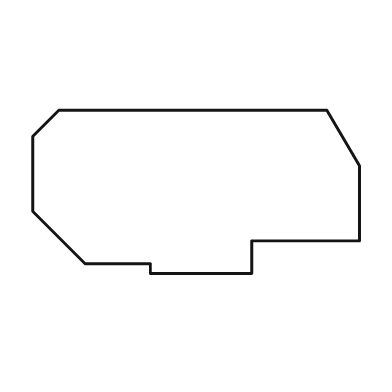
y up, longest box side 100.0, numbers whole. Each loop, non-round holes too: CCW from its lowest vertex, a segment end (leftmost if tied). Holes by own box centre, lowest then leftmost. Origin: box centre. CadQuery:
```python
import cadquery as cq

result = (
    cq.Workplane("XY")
    .moveTo(-14.0, -25.0)
    .lineTo(17.0, -25.0)
    .lineTo(17.0, -15.0)
    .lineTo(50.0, -15.0)
    .lineTo(50.0, 8.0)
    .lineTo(40.0, 25.0)
    .lineTo(-42.0, 25.0)
    .lineTo(-50.0, 17.0)
    .lineTo(-50.0, -6.0)
    .lineTo(-34.0, -22.0)
    .lineTo(-14.0, -22.0)
    .close()
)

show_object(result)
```